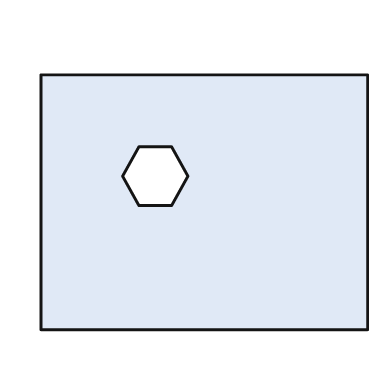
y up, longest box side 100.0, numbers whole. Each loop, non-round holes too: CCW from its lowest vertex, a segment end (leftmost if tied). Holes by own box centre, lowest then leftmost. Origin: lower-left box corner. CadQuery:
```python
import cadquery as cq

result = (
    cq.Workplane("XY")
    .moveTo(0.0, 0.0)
    .lineTo(100.0, 0.0)
    .lineTo(100.0, 78.0)
    .lineTo(0.0, 78.0)
    .close()
    .moveTo(30.0, 38.0)
    .lineTo(40.0, 38.0)
    .lineTo(45.0, 47.0)
    .lineTo(40.0, 56.0)
    .lineTo(30.0, 56.0)
    .lineTo(25.0, 47.0)
    .close()
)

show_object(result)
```